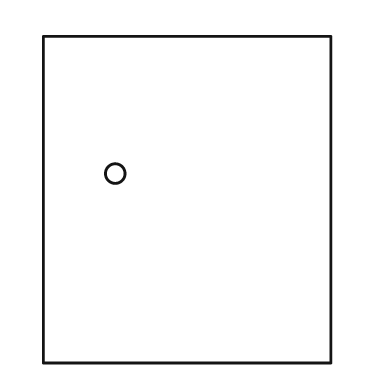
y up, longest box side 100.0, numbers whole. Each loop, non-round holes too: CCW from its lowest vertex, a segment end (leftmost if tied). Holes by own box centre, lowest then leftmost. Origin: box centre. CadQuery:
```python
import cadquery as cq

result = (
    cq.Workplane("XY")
    .moveTo(-44.0, -50.0)
    .lineTo(44.0, -50.0)
    .lineTo(44.0, 50.0)
    .lineTo(-44.0, 50.0)
    .close()
    .moveTo(-22.0, 8.0)
    .circle(3.0)
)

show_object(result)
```